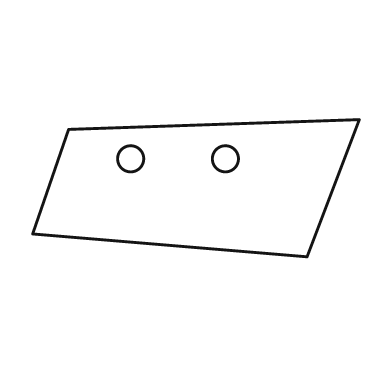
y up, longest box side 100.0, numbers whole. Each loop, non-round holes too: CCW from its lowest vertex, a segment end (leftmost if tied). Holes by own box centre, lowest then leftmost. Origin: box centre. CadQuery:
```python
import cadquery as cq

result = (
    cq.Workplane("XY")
    .moveTo(34.0, -21.0)
    .lineTo(50.0, 21.0)
    .lineTo(-39.0, 18.0)
    .lineTo(-50.0, -14.0)
    .close()
    .moveTo(-20.0, 9.0)
    .circle(4.0)
    .moveTo(9.0, 9.0)
    .circle(4.0)
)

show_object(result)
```